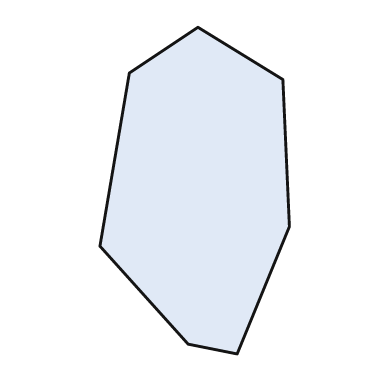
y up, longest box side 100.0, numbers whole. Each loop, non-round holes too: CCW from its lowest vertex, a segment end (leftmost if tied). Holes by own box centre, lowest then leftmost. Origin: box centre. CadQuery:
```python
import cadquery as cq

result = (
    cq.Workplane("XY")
    .moveTo(13.0, -50.0)
    .lineTo(29.0, -11.0)
    .lineTo(27.0, 34.0)
    .lineTo(1.0, 50.0)
    .lineTo(-20.0, 36.0)
    .lineTo(-29.0, -17.0)
    .lineTo(-2.0, -47.0)
    .close()
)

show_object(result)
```